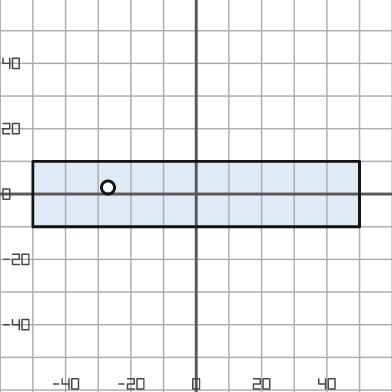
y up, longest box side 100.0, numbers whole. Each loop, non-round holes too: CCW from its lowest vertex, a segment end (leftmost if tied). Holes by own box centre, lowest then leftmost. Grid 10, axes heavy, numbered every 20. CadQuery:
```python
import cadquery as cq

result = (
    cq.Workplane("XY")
    .moveTo(-50.0, -10.0)
    .lineTo(50.0, -10.0)
    .lineTo(50.0, 10.0)
    .lineTo(-50.0, 10.0)
    .close()
    .moveTo(-27.0, 2.0)
    .circle(2.0)
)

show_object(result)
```